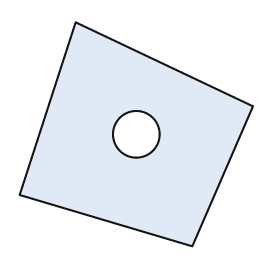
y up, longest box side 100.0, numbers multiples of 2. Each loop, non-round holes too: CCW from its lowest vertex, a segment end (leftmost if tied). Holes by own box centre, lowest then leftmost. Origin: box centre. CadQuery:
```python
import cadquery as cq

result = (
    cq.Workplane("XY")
    .moveTo(24.0, -48.0)
    .lineTo(50.0, 12.0)
    .lineTo(-26.0, 48.0)
    .lineTo(-50.0, -26.0)
    .close()
    .moveTo(0.0, 0.0)
    .circle(10.0)
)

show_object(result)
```